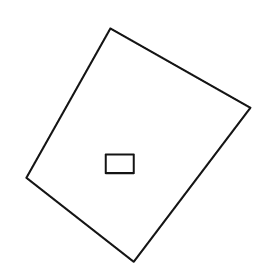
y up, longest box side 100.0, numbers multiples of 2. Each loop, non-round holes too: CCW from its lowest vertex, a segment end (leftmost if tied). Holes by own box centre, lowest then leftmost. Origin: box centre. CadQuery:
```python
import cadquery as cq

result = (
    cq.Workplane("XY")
    .moveTo(-2.0, -50.0)
    .lineTo(48.0, 16.0)
    .lineTo(-12.0, 50.0)
    .lineTo(-48.0, -14.0)
    .close()
    .moveTo(-14.0, -12.0)
    .lineTo(-2.0, -12.0)
    .lineTo(-2.0, -4.0)
    .lineTo(-14.0, -4.0)
    .close()
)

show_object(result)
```